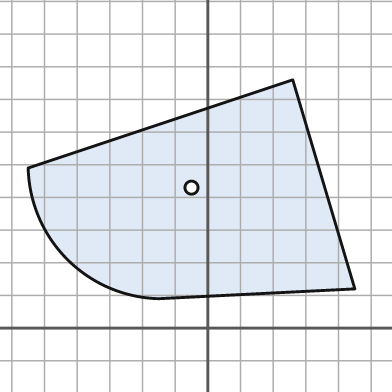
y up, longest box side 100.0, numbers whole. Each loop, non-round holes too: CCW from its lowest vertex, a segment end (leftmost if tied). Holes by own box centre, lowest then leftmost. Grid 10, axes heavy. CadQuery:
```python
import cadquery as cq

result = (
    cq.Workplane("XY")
    .moveTo(-15.0, 9.0)
    .lineTo(45.0, 12.0)
    .lineTo(26.0, 76.0)
    .lineTo(-55.0, 49.0)
    .threePointArc((-43.0, 21.0), (-15.0, 9.0))
    .close()
    .moveTo(-5.0, 43.0)
    .circle(2.0)
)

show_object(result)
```